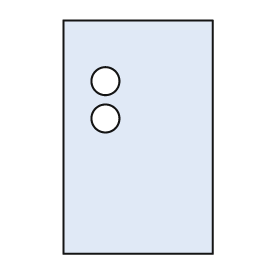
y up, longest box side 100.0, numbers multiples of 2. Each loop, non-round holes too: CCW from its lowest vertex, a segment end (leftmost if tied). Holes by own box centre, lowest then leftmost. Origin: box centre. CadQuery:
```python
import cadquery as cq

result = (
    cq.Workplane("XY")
    .moveTo(-32.0, -50.0)
    .lineTo(32.0, -50.0)
    .lineTo(32.0, 50.0)
    .lineTo(-32.0, 50.0)
    .close()
    .moveTo(-14.0, 8.0)
    .circle(6.0)
    .moveTo(-14.0, 24.0)
    .circle(6.0)
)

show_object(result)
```